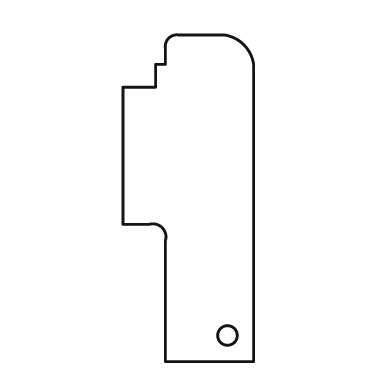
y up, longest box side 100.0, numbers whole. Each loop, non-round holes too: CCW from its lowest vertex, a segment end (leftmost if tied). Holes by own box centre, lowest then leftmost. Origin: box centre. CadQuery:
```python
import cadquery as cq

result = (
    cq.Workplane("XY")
    .moveTo(-7.0, -50.0)
    .lineTo(20.0, -50.0)
    .lineTo(20.0, 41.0)
    .threePointArc((17.0, 47.0), (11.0, 50.0))
    .lineTo(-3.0, 50.0)
    .threePointArc((-6.0, 49.0), (-7.0, 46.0))
    .lineTo(-7.0, 41.0)
    .lineTo(-10.0, 41.0)
    .lineTo(-10.0, 34.0)
    .lineTo(-20.0, 34.0)
    .lineTo(-20.0, -8.0)
    .lineTo(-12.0, -8.0)
    .threePointArc((-8.0, -9.0), (-7.0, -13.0))
    .close()
    .moveTo(12.0, -42.0)
    .circle(3.0)
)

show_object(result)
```